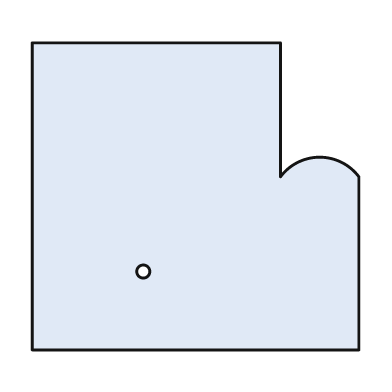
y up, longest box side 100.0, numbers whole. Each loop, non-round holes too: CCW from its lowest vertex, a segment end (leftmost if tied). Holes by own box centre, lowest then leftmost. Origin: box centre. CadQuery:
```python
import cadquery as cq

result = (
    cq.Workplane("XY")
    .moveTo(-50.0, -47.0)
    .lineTo(50.0, -47.0)
    .lineTo(50.0, 6.0)
    .threePointArc((38.0, 12.0), (26.0, 6.0))
    .lineTo(26.0, 47.0)
    .lineTo(-50.0, 47.0)
    .close()
    .moveTo(-16.0, -23.0)
    .circle(2.0)
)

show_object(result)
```